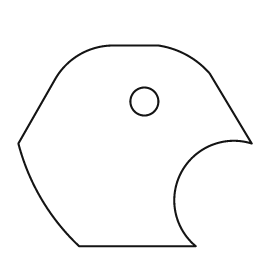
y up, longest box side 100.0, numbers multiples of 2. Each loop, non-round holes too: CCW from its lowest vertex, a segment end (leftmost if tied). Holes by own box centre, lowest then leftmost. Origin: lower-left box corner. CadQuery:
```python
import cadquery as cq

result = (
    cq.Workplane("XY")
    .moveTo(26.0, 0.0)
    .lineTo(76.0, 0.0)
    .threePointArc((70.0, 32.0), (100.0, 44.0))
    .lineTo(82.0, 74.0)
    .threePointArc((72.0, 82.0), (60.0, 86.0))
    .lineTo(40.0, 86.0)
    .threePointArc((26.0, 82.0), (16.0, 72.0))
    .lineTo(0.0, 44.0)
    .threePointArc((10.0, 20.0), (26.0, 0.0))
    .close()
    .moveTo(54.0, 62.0)
    .circle(6.0)
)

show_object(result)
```